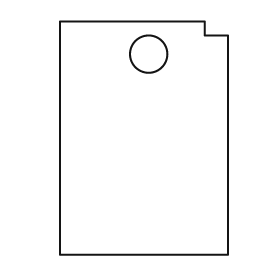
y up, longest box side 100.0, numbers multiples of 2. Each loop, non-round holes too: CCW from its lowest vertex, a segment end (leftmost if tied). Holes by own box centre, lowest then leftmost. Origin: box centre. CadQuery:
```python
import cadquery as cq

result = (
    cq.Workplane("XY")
    .moveTo(-36.0, -50.0)
    .lineTo(36.0, -50.0)
    .lineTo(36.0, 44.0)
    .lineTo(26.0, 44.0)
    .lineTo(26.0, 50.0)
    .lineTo(-36.0, 50.0)
    .close()
    .moveTo(2.0, 36.0)
    .circle(8.0)
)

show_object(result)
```